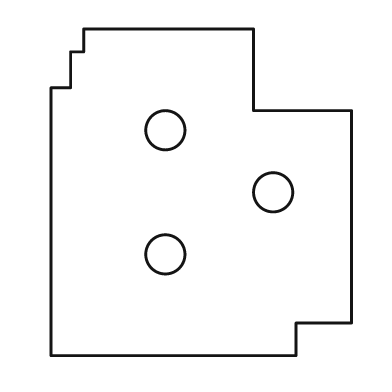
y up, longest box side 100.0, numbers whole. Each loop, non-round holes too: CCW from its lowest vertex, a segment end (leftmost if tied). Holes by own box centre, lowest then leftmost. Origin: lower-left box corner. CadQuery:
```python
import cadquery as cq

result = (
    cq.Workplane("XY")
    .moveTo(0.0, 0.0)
    .lineTo(75.0, 0.0)
    .lineTo(75.0, 10.0)
    .lineTo(92.0, 10.0)
    .lineTo(92.0, 75.0)
    .lineTo(62.0, 75.0)
    .lineTo(62.0, 100.0)
    .lineTo(10.0, 100.0)
    .lineTo(10.0, 93.0)
    .lineTo(6.0, 93.0)
    .lineTo(6.0, 82.0)
    .lineTo(0.0, 82.0)
    .close()
    .moveTo(35.0, 31.0)
    .circle(6.0)
    .moveTo(68.0, 50.0)
    .circle(6.0)
    .moveTo(35.0, 69.0)
    .circle(6.0)
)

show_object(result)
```